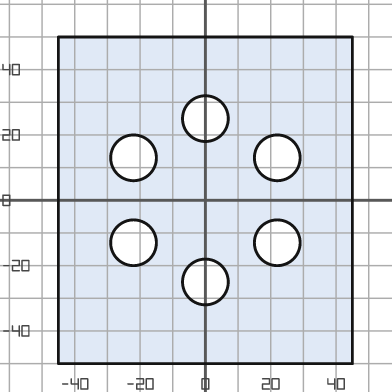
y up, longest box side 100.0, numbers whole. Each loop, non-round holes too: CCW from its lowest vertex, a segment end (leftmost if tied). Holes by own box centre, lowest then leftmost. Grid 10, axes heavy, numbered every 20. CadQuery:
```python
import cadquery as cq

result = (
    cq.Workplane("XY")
    .moveTo(-45.0, -50.0)
    .lineTo(45.0, -50.0)
    .lineTo(45.0, 50.0)
    .lineTo(-45.0, 50.0)
    .close()
    .moveTo(0.0, -25.0)
    .circle(7.0)
    .moveTo(-22.0, -13.0)
    .circle(7.0)
    .moveTo(22.0, -13.0)
    .circle(7.0)
    .moveTo(-22.0, 13.0)
    .circle(7.0)
    .moveTo(22.0, 13.0)
    .circle(7.0)
    .moveTo(0.0, 25.0)
    .circle(7.0)
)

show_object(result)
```